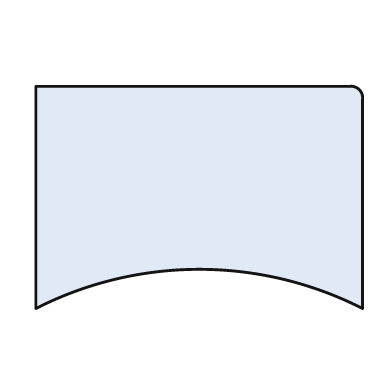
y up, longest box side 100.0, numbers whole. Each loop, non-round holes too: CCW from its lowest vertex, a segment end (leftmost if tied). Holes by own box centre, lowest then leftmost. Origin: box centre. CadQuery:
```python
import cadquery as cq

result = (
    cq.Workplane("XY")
    .moveTo(-50.0, -34.0)
    .threePointArc((0.0, -22.0), (50.0, -34.0))
    .lineTo(50.0, 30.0)
    .threePointArc((49.0, 33.0), (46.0, 34.0))
    .lineTo(-50.0, 34.0)
    .close()
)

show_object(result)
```